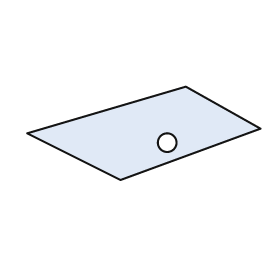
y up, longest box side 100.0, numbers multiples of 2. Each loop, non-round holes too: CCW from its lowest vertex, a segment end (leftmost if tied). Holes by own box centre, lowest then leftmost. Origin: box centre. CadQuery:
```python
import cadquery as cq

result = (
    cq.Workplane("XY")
    .moveTo(-10.0, -20.0)
    .lineTo(50.0, 2.0)
    .lineTo(18.0, 20.0)
    .lineTo(-50.0, 0.0)
    .close()
    .moveTo(10.0, -4.0)
    .circle(4.0)
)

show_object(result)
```